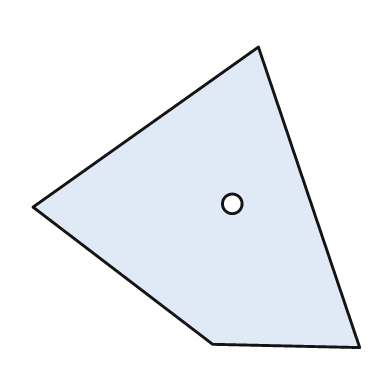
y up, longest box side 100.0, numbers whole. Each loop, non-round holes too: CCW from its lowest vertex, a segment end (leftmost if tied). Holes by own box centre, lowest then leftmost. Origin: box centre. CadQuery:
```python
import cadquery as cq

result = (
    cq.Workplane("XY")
    .moveTo(50.0, -46.0)
    .lineTo(19.0, 46.0)
    .lineTo(-50.0, -3.0)
    .lineTo(5.0, -45.0)
    .close()
    .moveTo(11.0, -2.0)
    .circle(3.0)
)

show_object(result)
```